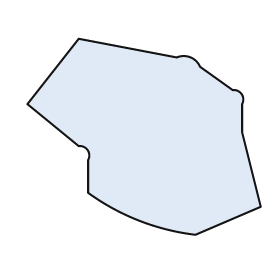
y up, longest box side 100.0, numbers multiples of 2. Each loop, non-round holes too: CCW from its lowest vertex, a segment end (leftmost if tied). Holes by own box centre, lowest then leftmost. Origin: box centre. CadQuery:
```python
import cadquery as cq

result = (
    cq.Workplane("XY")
    .moveTo(22.0, -42.0)
    .lineTo(50.0, -30.0)
    .lineTo(42.0, 2.0)
    .lineTo(42.0, 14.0)
    .threePointArc((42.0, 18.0), (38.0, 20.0))
    .lineTo(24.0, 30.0)
    .threePointArc((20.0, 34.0), (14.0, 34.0))
    .lineTo(-28.0, 42.0)
    .lineTo(-50.0, 14.0)
    .lineTo(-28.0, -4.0)
    .threePointArc((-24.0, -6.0), (-24.0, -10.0))
    .lineTo(-24.0, -24.0)
    .threePointArc((-2.0, -36.0), (22.0, -42.0))
    .close()
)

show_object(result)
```